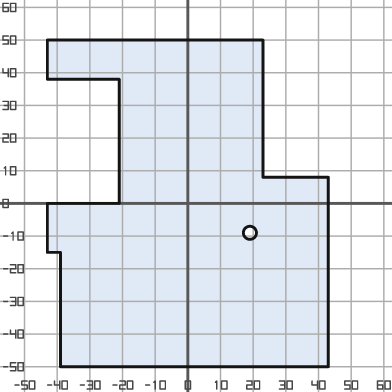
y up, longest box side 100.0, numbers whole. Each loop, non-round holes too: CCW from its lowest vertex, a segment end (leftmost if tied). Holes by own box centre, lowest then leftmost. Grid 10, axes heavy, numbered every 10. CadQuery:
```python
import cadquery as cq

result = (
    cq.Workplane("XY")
    .moveTo(-39.0, -50.0)
    .lineTo(43.0, -50.0)
    .lineTo(43.0, 8.0)
    .lineTo(23.0, 8.0)
    .lineTo(23.0, 50.0)
    .lineTo(-43.0, 50.0)
    .lineTo(-43.0, 38.0)
    .lineTo(-21.0, 38.0)
    .lineTo(-21.0, 0.0)
    .lineTo(-43.0, 0.0)
    .lineTo(-43.0, -15.0)
    .lineTo(-39.0, -15.0)
    .close()
    .moveTo(19.0, -9.0)
    .circle(2.0)
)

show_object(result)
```